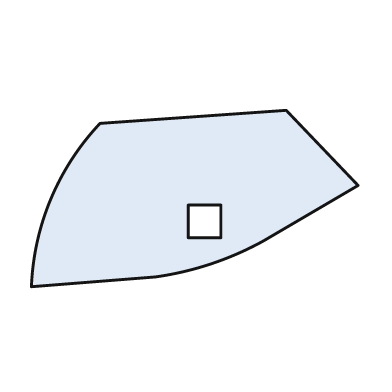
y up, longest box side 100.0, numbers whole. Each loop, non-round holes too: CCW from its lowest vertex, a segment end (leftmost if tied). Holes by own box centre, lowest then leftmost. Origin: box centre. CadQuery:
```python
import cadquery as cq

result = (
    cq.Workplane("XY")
    .moveTo(-50.0, -27.0)
    .lineTo(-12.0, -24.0)
    .threePointArc((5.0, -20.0), (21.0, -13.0))
    .lineTo(50.0, 4.0)
    .lineTo(28.0, 27.0)
    .lineTo(-29.0, 23.0)
    .threePointArc((-44.0, 0.0), (-50.0, -27.0))
    .close()
    .moveTo(-2.0, -12.0)
    .lineTo(8.0, -12.0)
    .lineTo(8.0, -2.0)
    .lineTo(-2.0, -2.0)
    .close()
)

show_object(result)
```